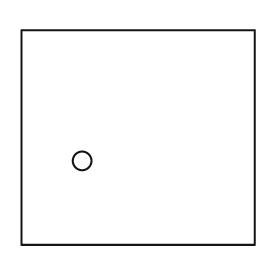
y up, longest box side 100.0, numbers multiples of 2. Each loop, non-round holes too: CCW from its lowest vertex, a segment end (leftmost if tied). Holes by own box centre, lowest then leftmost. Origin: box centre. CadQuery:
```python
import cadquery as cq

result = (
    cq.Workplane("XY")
    .moveTo(-50.0, -46.0)
    .lineTo(50.0, -46.0)
    .lineTo(50.0, 46.0)
    .lineTo(-50.0, 46.0)
    .close()
    .moveTo(-24.0, -10.0)
    .circle(4.0)
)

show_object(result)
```